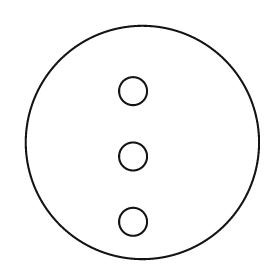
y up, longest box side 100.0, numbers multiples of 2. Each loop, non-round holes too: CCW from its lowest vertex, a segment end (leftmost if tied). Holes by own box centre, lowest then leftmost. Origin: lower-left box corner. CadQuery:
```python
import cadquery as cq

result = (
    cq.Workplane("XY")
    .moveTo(50.0, 50.0)
    .circle(50.0)
    .moveTo(46.0, 16.0)
    .circle(6.0)
    .moveTo(46.0, 44.0)
    .circle(6.0)
    .moveTo(46.0, 72.0)
    .circle(6.0)
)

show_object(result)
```